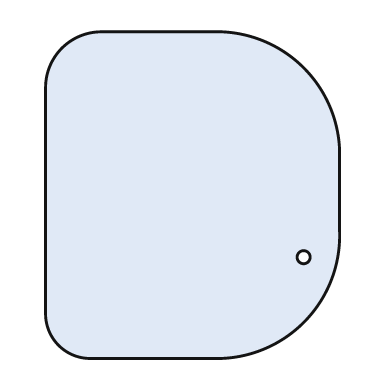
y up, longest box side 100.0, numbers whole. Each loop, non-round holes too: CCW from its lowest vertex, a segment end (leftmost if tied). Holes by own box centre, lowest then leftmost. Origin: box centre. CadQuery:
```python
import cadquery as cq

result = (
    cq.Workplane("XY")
    .moveTo(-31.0, -50.0)
    .lineTo(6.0, -50.0)
    .threePointArc((34.0, -39.0), (45.0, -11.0))
    .lineTo(45.0, 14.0)
    .threePointArc((34.0, 39.0), (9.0, 50.0))
    .lineTo(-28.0, 50.0)
    .threePointArc((-40.0, 45.0), (-45.0, 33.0))
    .lineTo(-45.0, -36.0)
    .threePointArc((-41.0, -46.0), (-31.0, -50.0))
    .close()
    .moveTo(34.0, -19.0)
    .circle(2.0)
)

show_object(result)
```